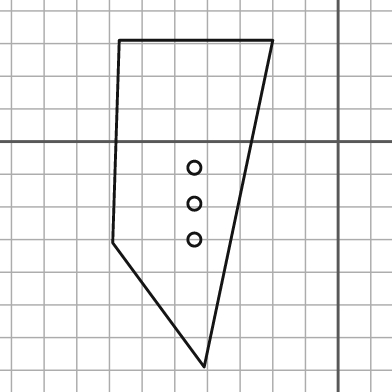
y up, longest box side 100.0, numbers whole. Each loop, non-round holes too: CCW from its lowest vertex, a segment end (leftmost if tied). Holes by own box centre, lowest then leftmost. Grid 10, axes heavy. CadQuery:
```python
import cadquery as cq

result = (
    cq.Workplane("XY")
    .moveTo(-41.0, -69.0)
    .lineTo(-20.0, 31.0)
    .lineTo(-67.0, 31.0)
    .lineTo(-69.0, -31.0)
    .close()
    .moveTo(-44.0, -30.0)
    .circle(2.0)
    .moveTo(-44.0, -19.0)
    .circle(2.0)
    .moveTo(-44.0, -8.0)
    .circle(2.0)
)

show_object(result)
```